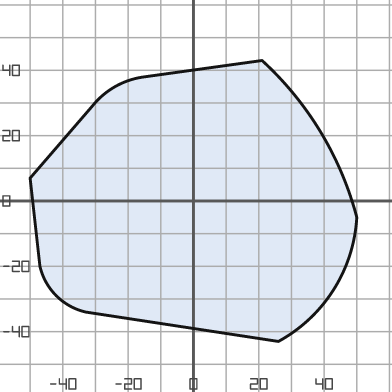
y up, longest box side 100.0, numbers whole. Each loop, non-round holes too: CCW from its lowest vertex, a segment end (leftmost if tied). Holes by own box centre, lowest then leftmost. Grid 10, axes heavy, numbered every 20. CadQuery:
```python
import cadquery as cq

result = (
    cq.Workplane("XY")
    .moveTo(26.0, -43.0)
    .threePointArc((43.0, -27.0), (50.0, -5.0))
    .threePointArc((39.0, 21.0), (21.0, 43.0))
    .lineTo(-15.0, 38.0)
    .threePointArc((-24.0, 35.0), (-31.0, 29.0))
    .lineTo(-50.0, 7.0)
    .lineTo(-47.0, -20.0)
    .threePointArc((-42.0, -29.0), (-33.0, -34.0))
    .close()
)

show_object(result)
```